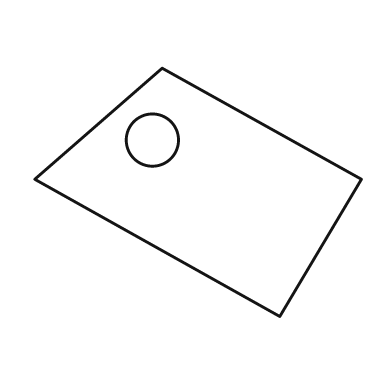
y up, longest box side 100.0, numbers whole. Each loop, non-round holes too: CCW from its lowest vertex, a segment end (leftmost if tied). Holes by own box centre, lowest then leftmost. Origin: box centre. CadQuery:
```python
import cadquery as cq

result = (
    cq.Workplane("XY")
    .moveTo(25.0, -38.0)
    .lineTo(50.0, 4.0)
    .lineTo(-11.0, 38.0)
    .lineTo(-50.0, 4.0)
    .close()
    .moveTo(-14.0, 16.0)
    .circle(8.0)
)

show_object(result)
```